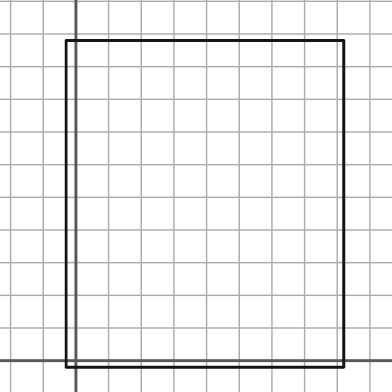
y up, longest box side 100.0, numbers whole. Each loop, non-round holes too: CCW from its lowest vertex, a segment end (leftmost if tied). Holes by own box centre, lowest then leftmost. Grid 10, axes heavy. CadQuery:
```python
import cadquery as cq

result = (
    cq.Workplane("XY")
    .moveTo(-3.0, -2.0)
    .lineTo(82.0, -2.0)
    .lineTo(82.0, 98.0)
    .lineTo(-3.0, 98.0)
    .close()
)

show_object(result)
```